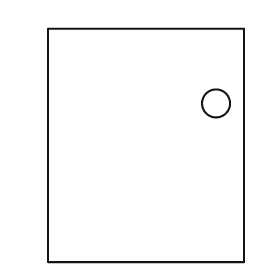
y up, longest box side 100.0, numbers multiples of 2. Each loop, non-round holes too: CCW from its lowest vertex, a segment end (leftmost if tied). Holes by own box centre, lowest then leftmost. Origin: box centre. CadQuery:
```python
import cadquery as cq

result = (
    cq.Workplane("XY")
    .moveTo(-42.0, -50.0)
    .lineTo(42.0, -50.0)
    .lineTo(42.0, 50.0)
    .lineTo(-42.0, 50.0)
    .close()
    .moveTo(30.0, 18.0)
    .circle(6.0)
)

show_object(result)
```